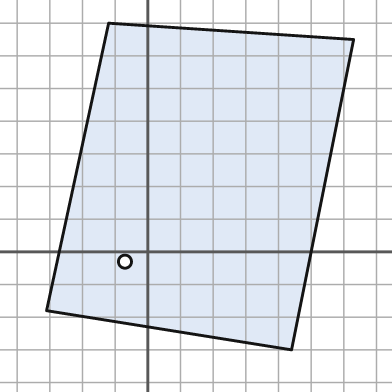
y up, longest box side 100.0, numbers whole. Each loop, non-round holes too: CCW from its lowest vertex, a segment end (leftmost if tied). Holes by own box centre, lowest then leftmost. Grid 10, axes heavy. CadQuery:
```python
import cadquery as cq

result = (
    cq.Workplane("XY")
    .moveTo(44.0, -30.0)
    .lineTo(63.0, 65.0)
    .lineTo(-12.0, 70.0)
    .lineTo(-31.0, -18.0)
    .close()
    .moveTo(-7.0, -3.0)
    .circle(2.0)
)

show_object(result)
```